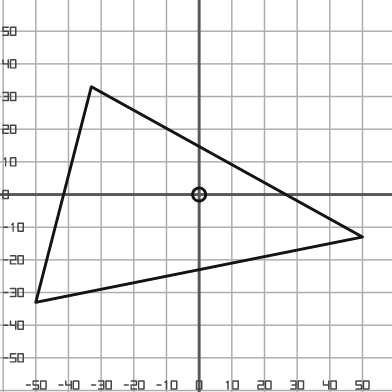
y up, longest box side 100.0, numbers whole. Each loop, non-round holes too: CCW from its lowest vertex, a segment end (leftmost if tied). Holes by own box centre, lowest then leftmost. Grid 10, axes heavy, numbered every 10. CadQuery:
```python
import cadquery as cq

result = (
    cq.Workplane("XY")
    .moveTo(-50.0, -33.0)
    .lineTo(50.0, -13.0)
    .lineTo(-33.0, 33.0)
    .close()
    .moveTo(0.0, 0.0)
    .circle(2.0)
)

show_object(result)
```